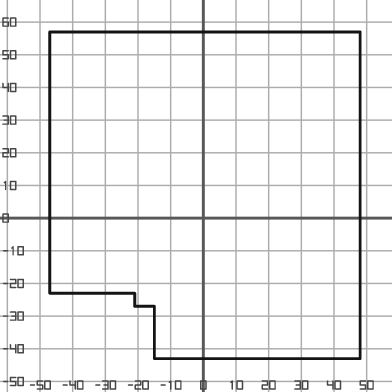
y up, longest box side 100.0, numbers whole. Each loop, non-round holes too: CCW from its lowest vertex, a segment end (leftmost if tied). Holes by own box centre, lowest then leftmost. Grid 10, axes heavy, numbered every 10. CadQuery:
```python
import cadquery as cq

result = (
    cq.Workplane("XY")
    .moveTo(-15.0, -43.0)
    .lineTo(48.0, -43.0)
    .lineTo(48.0, 57.0)
    .lineTo(-47.0, 57.0)
    .lineTo(-47.0, -23.0)
    .lineTo(-21.0, -23.0)
    .lineTo(-21.0, -27.0)
    .lineTo(-15.0, -27.0)
    .close()
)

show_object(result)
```